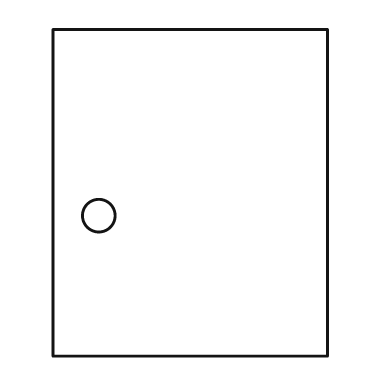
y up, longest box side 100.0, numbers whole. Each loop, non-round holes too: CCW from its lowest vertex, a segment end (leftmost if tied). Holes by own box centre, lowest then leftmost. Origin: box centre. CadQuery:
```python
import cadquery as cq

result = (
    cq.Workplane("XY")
    .moveTo(-42.0, -50.0)
    .lineTo(42.0, -50.0)
    .lineTo(42.0, 50.0)
    .lineTo(-42.0, 50.0)
    .close()
    .moveTo(-28.0, -7.0)
    .circle(5.0)
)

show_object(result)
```